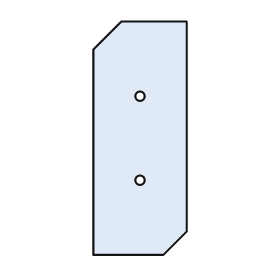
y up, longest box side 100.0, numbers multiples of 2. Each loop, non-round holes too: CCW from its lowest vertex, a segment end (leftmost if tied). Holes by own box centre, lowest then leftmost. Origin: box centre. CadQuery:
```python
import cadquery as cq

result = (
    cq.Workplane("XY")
    .moveTo(-20.0, -50.0)
    .lineTo(10.0, -50.0)
    .lineTo(20.0, -40.0)
    .lineTo(20.0, 50.0)
    .lineTo(-8.0, 50.0)
    .lineTo(-20.0, 38.0)
    .close()
    .moveTo(0.0, -18.0)
    .circle(2.0)
    .moveTo(0.0, 18.0)
    .circle(2.0)
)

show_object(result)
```